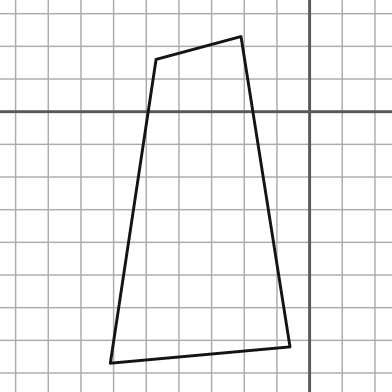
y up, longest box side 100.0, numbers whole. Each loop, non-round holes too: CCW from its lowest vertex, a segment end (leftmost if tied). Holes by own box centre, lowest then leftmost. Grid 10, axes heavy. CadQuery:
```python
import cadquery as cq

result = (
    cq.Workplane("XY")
    .moveTo(-61.0, -77.0)
    .lineTo(-6.0, -72.0)
    .lineTo(-21.0, 23.0)
    .lineTo(-47.0, 16.0)
    .close()
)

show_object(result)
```